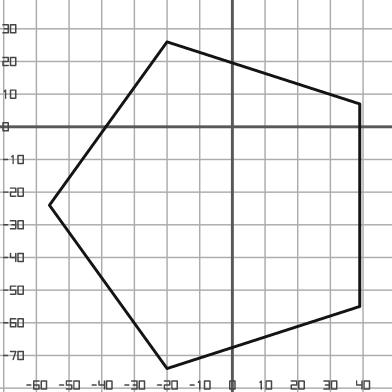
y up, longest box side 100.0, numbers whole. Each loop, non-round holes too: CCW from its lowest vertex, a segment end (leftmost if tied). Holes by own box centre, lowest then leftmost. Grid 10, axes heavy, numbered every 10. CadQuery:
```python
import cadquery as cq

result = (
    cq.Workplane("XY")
    .moveTo(-20.0, -74.0)
    .lineTo(39.0, -55.0)
    .lineTo(39.0, 7.0)
    .lineTo(-20.0, 26.0)
    .lineTo(-56.0, -24.0)
    .close()
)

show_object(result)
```